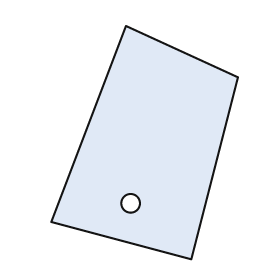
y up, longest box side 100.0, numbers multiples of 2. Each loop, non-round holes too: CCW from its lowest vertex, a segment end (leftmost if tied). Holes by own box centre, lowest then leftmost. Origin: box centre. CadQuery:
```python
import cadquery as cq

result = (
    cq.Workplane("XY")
    .moveTo(20.0, -50.0)
    .lineTo(40.0, 28.0)
    .lineTo(-8.0, 50.0)
    .lineTo(-40.0, -34.0)
    .close()
    .moveTo(-6.0, -26.0)
    .circle(4.0)
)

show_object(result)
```